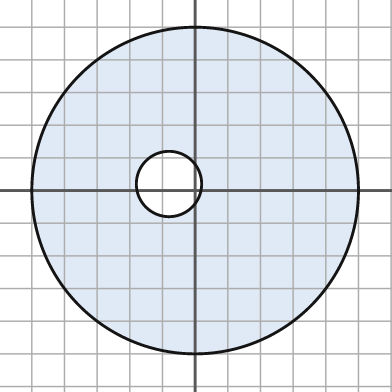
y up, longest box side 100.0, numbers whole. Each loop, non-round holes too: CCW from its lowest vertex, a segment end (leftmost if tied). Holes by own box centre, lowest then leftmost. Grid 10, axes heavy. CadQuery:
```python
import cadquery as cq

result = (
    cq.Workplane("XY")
    .moveTo(0.0, 0.0)
    .circle(50.0)
    .moveTo(-8.0, 2.0)
    .circle(10.0)
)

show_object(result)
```